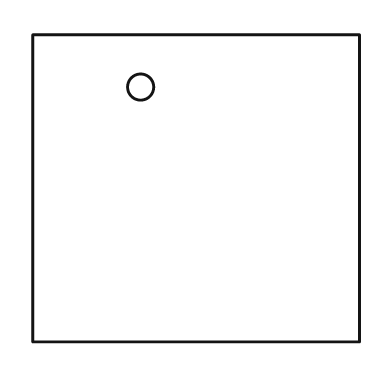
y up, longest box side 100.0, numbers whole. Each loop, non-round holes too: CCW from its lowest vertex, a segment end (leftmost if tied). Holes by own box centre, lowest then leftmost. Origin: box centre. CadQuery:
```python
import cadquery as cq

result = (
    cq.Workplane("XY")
    .moveTo(-50.0, -47.0)
    .lineTo(50.0, -47.0)
    .lineTo(50.0, 47.0)
    .lineTo(-50.0, 47.0)
    .close()
    .moveTo(-17.0, 31.0)
    .circle(4.0)
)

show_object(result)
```